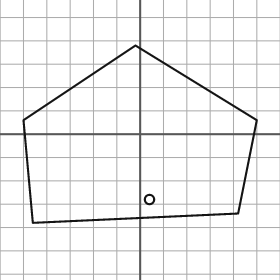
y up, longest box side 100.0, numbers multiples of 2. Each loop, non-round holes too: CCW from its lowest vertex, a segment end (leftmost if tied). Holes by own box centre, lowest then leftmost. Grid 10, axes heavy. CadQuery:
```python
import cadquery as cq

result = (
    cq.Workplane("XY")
    .moveTo(-46.0, -38.0)
    .lineTo(42.0, -34.0)
    .lineTo(50.0, 6.0)
    .lineTo(-2.0, 38.0)
    .lineTo(-50.0, 6.0)
    .close()
    .moveTo(4.0, -28.0)
    .circle(2.0)
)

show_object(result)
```